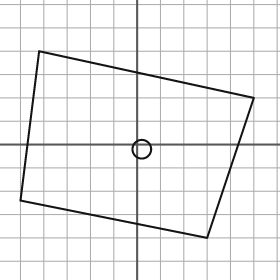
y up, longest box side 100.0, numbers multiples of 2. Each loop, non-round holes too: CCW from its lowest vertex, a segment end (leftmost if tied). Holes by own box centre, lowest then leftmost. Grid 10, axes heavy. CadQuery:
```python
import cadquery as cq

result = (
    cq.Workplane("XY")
    .moveTo(30.0, -40.0)
    .lineTo(50.0, 20.0)
    .lineTo(-42.0, 40.0)
    .lineTo(-50.0, -24.0)
    .close()
    .moveTo(2.0, -2.0)
    .circle(4.0)
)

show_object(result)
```